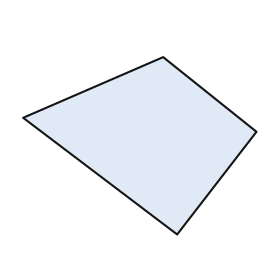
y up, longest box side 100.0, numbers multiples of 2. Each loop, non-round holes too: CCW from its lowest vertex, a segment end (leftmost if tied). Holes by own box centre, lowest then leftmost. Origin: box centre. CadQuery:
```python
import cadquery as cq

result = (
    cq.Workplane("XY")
    .moveTo(16.0, -38.0)
    .lineTo(50.0, 6.0)
    .lineTo(10.0, 38.0)
    .lineTo(-50.0, 12.0)
    .close()
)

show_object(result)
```